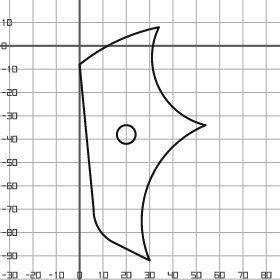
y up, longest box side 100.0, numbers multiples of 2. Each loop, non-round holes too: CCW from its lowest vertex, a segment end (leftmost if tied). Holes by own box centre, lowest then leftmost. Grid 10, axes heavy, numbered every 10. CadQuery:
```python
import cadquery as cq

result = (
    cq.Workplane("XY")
    .moveTo(30.0, -92.0)
    .threePointArc((30.0, -58.0), (54.0, -34.0))
    .threePointArc((34.0, -18.0), (34.0, 8.0))
    .threePointArc((16.0, 2.0), (0.0, -8.0))
    .lineTo(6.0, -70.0)
    .threePointArc((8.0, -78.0), (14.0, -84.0))
    .close()
    .moveTo(20.0, -38.0)
    .circle(4.0)
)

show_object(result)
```